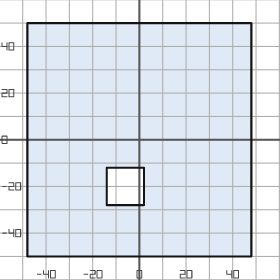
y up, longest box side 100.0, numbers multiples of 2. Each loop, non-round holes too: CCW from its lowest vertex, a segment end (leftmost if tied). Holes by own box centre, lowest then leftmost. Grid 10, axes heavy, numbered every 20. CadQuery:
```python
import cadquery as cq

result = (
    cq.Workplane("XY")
    .moveTo(-48.0, -50.0)
    .lineTo(48.0, -50.0)
    .lineTo(48.0, 50.0)
    .lineTo(-48.0, 50.0)
    .close()
    .moveTo(-14.0, -28.0)
    .lineTo(2.0, -28.0)
    .lineTo(2.0, -12.0)
    .lineTo(-14.0, -12.0)
    .close()
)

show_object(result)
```